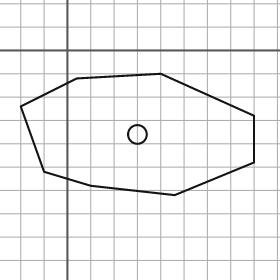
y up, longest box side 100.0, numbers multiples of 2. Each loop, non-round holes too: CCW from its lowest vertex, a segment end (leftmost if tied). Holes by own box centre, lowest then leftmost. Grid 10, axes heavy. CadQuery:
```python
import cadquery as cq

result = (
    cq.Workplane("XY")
    .moveTo(46.0, -62.0)
    .lineTo(80.0, -48.0)
    .lineTo(80.0, -28.0)
    .lineTo(40.0, -10.0)
    .lineTo(4.0, -12.0)
    .lineTo(-20.0, -24.0)
    .lineTo(-10.0, -52.0)
    .lineTo(10.0, -58.0)
    .close()
    .moveTo(30.0, -36.0)
    .circle(4.0)
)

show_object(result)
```